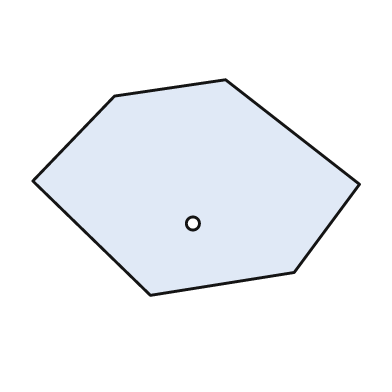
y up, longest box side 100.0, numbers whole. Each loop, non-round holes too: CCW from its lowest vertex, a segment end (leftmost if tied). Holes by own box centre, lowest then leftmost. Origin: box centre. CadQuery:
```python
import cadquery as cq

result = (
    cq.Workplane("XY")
    .moveTo(-14.0, -33.0)
    .lineTo(30.0, -26.0)
    .lineTo(50.0, 1.0)
    .lineTo(9.0, 33.0)
    .lineTo(-25.0, 28.0)
    .lineTo(-50.0, 2.0)
    .close()
    .moveTo(-1.0, -11.0)
    .circle(2.0)
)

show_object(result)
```